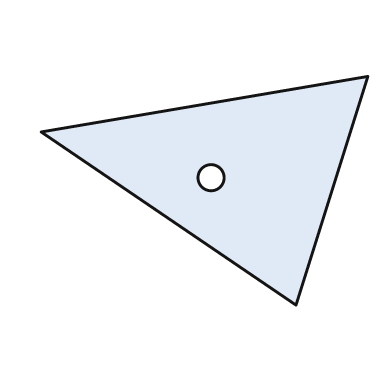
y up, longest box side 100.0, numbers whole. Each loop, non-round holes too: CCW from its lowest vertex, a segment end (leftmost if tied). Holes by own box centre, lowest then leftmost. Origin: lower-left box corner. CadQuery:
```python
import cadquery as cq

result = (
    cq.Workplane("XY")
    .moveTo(78.0, 0.0)
    .lineTo(100.0, 70.0)
    .lineTo(0.0, 53.0)
    .close()
    .moveTo(52.0, 39.0)
    .circle(4.0)
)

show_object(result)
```